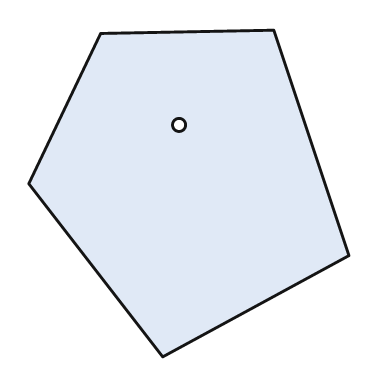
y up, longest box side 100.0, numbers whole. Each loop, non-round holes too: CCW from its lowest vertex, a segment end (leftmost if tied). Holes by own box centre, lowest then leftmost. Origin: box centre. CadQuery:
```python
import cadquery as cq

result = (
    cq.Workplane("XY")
    .moveTo(-8.0, -50.0)
    .lineTo(49.0, -19.0)
    .lineTo(26.0, 50.0)
    .lineTo(-27.0, 49.0)
    .lineTo(-49.0, 3.0)
    .close()
    .moveTo(-3.0, 21.0)
    .circle(2.0)
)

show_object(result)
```